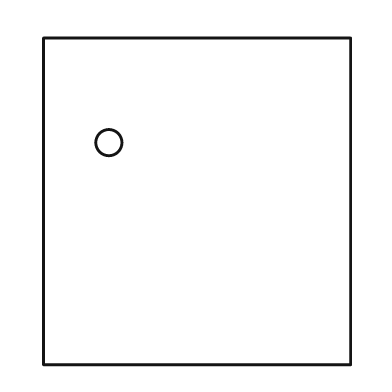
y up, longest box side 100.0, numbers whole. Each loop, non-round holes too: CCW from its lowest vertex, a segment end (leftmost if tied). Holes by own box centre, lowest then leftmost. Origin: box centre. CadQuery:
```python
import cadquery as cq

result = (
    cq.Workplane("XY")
    .moveTo(-47.0, -50.0)
    .lineTo(47.0, -50.0)
    .lineTo(47.0, 50.0)
    .lineTo(-47.0, 50.0)
    .close()
    .moveTo(-27.0, 18.0)
    .circle(4.0)
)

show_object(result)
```